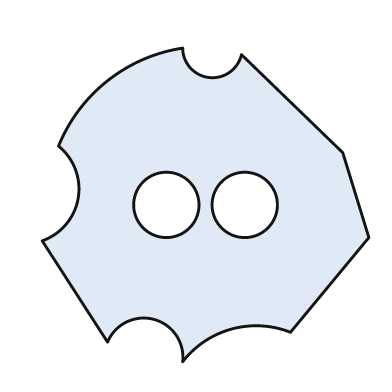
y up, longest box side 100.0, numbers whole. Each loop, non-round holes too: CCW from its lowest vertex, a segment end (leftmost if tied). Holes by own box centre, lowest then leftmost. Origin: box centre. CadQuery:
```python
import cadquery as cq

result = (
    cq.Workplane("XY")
    .moveTo(-7.0, -48.0)
    .threePointArc((8.0, -38.0), (26.0, -39.0))
    .lineTo(50.0, -10.0)
    .lineTo(42.0, 16.0)
    .lineTo(11.0, 46.0)
    .threePointArc((1.0, 39.0), (-7.0, 48.0))
    .threePointArc((-30.0, 38.0), (-45.0, 18.0))
    .threePointArc((-39.0, 2.0), (-50.0, -11.0))
    .lineTo(-30.0, -42.0)
    .threePointArc((-16.0, -35.0), (-7.0, -48.0))
    .close()
    .moveTo(-12.0, 0.0)
    .circle(10.0)
    .moveTo(12.0, 0.0)
    .circle(10.0)
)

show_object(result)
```